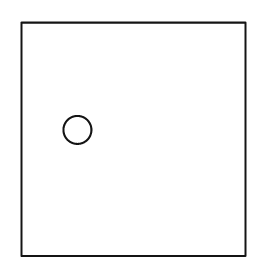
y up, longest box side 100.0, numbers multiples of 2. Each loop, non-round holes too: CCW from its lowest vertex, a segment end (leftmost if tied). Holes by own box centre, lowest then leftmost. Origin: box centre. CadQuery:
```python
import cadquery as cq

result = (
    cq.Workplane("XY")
    .moveTo(-48.0, -50.0)
    .lineTo(48.0, -50.0)
    .lineTo(48.0, 50.0)
    .lineTo(-48.0, 50.0)
    .close()
    .moveTo(-24.0, 4.0)
    .circle(6.0)
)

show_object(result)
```